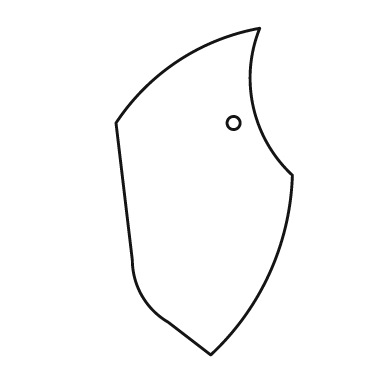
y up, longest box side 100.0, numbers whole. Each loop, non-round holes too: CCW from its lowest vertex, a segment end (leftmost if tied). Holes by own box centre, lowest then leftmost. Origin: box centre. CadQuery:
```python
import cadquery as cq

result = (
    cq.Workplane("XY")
    .moveTo(2.0, -50.0)
    .threePointArc((20.0, -25.0), (27.0, 5.0))
    .threePointArc((15.0, 26.0), (17.0, 50.0))
    .threePointArc((-8.0, 40.0), (-27.0, 21.0))
    .lineTo(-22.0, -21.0)
    .threePointArc((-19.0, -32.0), (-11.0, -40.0))
    .close()
    .moveTo(9.0, 21.0)
    .circle(2.0)
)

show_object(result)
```